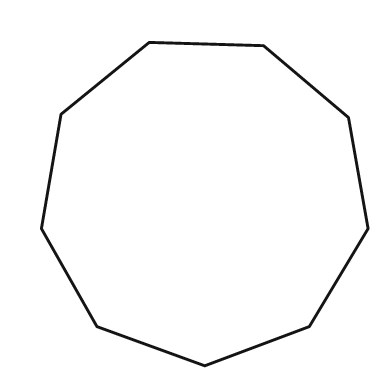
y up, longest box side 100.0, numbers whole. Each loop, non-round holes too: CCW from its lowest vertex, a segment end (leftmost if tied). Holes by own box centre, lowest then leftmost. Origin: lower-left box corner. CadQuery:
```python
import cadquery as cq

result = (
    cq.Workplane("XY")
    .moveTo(50.0, 0.0)
    .lineTo(82.0, 12.0)
    .lineTo(100.0, 42.0)
    .lineTo(94.0, 76.0)
    .lineTo(68.0, 98.0)
    .lineTo(33.0, 99.0)
    .lineTo(6.0, 77.0)
    .lineTo(0.0, 42.0)
    .lineTo(17.0, 12.0)
    .close()
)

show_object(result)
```